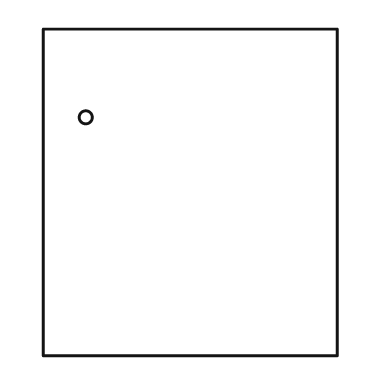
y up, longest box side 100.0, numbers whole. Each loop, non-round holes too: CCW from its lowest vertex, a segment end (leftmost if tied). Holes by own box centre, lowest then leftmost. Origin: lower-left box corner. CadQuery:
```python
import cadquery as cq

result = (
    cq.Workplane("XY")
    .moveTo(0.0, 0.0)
    .lineTo(90.0, 0.0)
    .lineTo(90.0, 100.0)
    .lineTo(0.0, 100.0)
    .close()
    .moveTo(13.0, 73.0)
    .circle(2.0)
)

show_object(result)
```